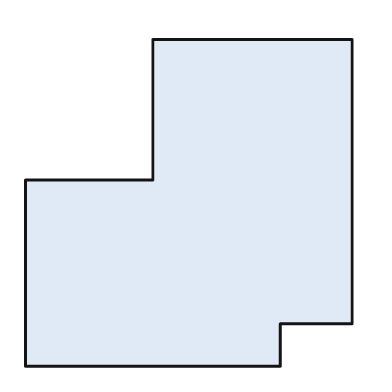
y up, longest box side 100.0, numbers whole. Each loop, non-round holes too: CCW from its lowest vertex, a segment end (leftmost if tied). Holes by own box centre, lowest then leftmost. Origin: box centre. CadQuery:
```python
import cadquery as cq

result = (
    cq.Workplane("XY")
    .moveTo(-50.0, -50.0)
    .lineTo(28.0, -50.0)
    .lineTo(28.0, -37.0)
    .lineTo(50.0, -37.0)
    .lineTo(50.0, 50.0)
    .lineTo(-11.0, 50.0)
    .lineTo(-11.0, 7.0)
    .lineTo(-50.0, 7.0)
    .close()
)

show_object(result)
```